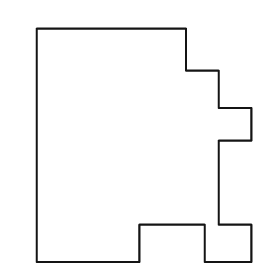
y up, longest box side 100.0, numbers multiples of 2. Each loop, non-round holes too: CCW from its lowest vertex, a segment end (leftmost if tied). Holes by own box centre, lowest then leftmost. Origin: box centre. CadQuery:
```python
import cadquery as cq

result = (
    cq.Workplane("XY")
    .moveTo(-46.0, -50.0)
    .lineTo(-2.0, -50.0)
    .lineTo(-2.0, -34.0)
    .lineTo(26.0, -34.0)
    .lineTo(26.0, -50.0)
    .lineTo(46.0, -50.0)
    .lineTo(46.0, -34.0)
    .lineTo(32.0, -34.0)
    .lineTo(32.0, 2.0)
    .lineTo(46.0, 2.0)
    .lineTo(46.0, 16.0)
    .lineTo(32.0, 16.0)
    .lineTo(32.0, 32.0)
    .lineTo(18.0, 32.0)
    .lineTo(18.0, 50.0)
    .lineTo(-46.0, 50.0)
    .close()
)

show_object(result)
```